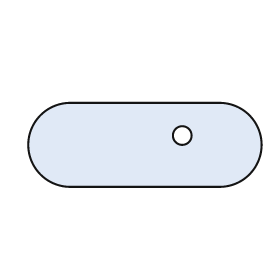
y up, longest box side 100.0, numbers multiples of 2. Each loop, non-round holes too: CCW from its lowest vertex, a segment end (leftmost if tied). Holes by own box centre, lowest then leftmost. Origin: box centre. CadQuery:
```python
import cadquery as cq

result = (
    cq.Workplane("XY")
    .moveTo(-32.0, -18.0)
    .lineTo(32.0, -18.0)
    .threePointArc((50.0, 0.0), (32.0, 18.0))
    .lineTo(-32.0, 18.0)
    .threePointArc((-50.0, 0.0), (-32.0, -18.0))
    .close()
    .moveTo(16.0, 4.0)
    .circle(4.0)
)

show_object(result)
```